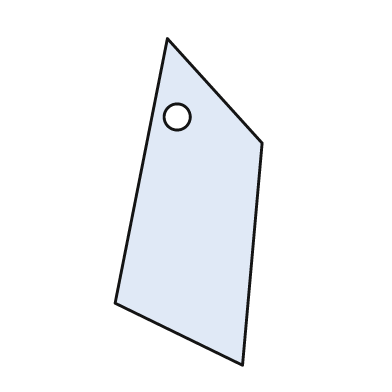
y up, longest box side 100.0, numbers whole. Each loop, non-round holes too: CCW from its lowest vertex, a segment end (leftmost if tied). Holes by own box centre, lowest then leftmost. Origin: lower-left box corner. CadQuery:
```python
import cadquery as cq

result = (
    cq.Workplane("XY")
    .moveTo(39.0, 0.0)
    .lineTo(45.0, 68.0)
    .lineTo(16.0, 100.0)
    .lineTo(0.0, 19.0)
    .close()
    .moveTo(19.0, 76.0)
    .circle(4.0)
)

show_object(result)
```